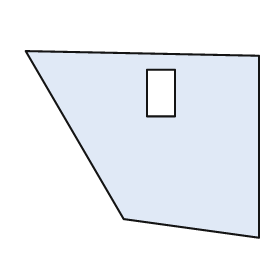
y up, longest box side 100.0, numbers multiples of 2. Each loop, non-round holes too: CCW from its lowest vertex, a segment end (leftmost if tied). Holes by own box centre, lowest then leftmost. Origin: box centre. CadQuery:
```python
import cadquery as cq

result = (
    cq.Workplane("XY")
    .moveTo(50.0, -40.0)
    .lineTo(50.0, 38.0)
    .lineTo(-50.0, 40.0)
    .lineTo(-8.0, -32.0)
    .close()
    .moveTo(2.0, 12.0)
    .lineTo(14.0, 12.0)
    .lineTo(14.0, 32.0)
    .lineTo(2.0, 32.0)
    .close()
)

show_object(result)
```